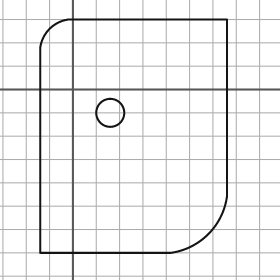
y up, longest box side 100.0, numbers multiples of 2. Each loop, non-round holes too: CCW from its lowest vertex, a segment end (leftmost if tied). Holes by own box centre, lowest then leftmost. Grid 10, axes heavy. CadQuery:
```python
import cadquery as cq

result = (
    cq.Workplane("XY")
    .moveTo(-14.0, -70.0)
    .lineTo(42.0, -70.0)
    .threePointArc((58.0, -62.0), (66.0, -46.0))
    .lineTo(66.0, 30.0)
    .lineTo(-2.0, 30.0)
    .threePointArc((-10.0, 26.0), (-14.0, 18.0))
    .close()
    .moveTo(16.0, -10.0)
    .circle(6.0)
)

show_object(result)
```